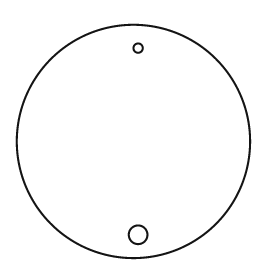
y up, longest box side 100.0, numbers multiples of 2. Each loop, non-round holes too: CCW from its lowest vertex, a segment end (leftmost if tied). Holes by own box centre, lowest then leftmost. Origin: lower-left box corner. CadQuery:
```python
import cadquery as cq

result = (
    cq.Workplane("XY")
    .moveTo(50.0, 50.0)
    .circle(50.0)
    .moveTo(52.0, 10.0)
    .circle(4.0)
    .moveTo(52.0, 90.0)
    .circle(2.0)
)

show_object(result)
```